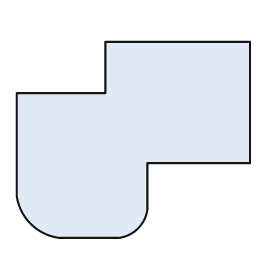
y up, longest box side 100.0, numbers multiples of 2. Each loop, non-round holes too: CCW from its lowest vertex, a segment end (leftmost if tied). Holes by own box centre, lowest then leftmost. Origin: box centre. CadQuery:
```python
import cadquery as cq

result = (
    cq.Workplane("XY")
    .moveTo(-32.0, -42.0)
    .lineTo(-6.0, -42.0)
    .threePointArc((2.0, -38.0), (6.0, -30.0))
    .lineTo(6.0, -10.0)
    .lineTo(50.0, -10.0)
    .lineTo(50.0, 42.0)
    .lineTo(-12.0, 42.0)
    .lineTo(-12.0, 20.0)
    .lineTo(-50.0, 20.0)
    .lineTo(-50.0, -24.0)
    .threePointArc((-44.0, -36.0), (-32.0, -42.0))
    .close()
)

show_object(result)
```